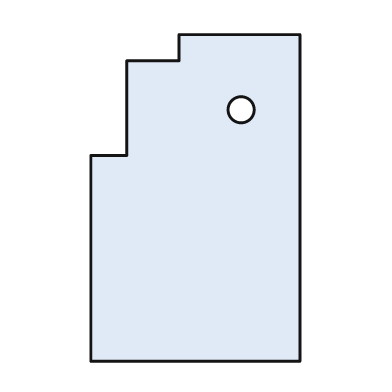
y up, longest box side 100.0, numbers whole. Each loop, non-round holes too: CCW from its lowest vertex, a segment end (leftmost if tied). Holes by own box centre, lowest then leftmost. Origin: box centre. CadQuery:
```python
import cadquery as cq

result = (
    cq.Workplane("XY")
    .moveTo(-32.0, -50.0)
    .lineTo(32.0, -50.0)
    .lineTo(32.0, 50.0)
    .lineTo(-5.0, 50.0)
    .lineTo(-5.0, 42.0)
    .lineTo(-21.0, 42.0)
    .lineTo(-21.0, 13.0)
    .lineTo(-32.0, 13.0)
    .close()
    .moveTo(14.0, 27.0)
    .circle(4.0)
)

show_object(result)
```